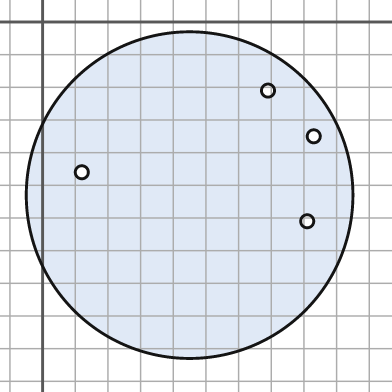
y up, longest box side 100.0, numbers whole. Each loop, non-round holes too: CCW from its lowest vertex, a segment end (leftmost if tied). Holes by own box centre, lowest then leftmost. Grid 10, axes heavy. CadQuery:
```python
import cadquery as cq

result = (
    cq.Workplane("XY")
    .moveTo(45.0, -53.0)
    .circle(50.0)
    .moveTo(81.0, -61.0)
    .circle(2.0)
    .moveTo(12.0, -46.0)
    .circle(2.0)
    .moveTo(83.0, -35.0)
    .circle(2.0)
    .moveTo(69.0, -21.0)
    .circle(2.0)
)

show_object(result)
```